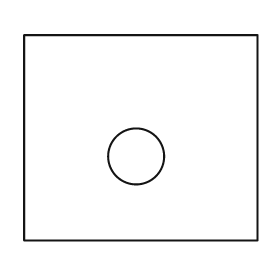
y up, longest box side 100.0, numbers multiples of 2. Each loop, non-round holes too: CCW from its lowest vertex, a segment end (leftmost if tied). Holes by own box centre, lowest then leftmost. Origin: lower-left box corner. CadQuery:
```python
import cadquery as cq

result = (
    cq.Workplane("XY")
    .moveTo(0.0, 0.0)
    .lineTo(100.0, 0.0)
    .lineTo(100.0, 88.0)
    .lineTo(0.0, 88.0)
    .close()
    .moveTo(48.0, 36.0)
    .circle(12.0)
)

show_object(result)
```